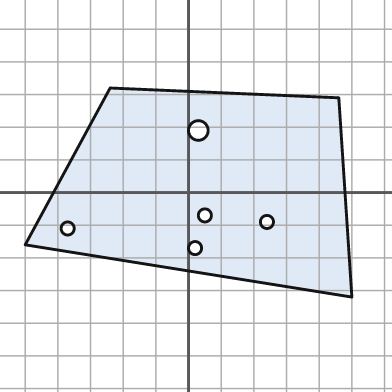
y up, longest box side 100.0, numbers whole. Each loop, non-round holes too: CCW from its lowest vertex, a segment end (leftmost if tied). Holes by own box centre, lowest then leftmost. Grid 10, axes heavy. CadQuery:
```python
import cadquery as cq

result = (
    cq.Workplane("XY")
    .moveTo(50.0, -32.0)
    .lineTo(46.0, 29.0)
    .lineTo(-24.0, 32.0)
    .lineTo(-50.0, -16.0)
    .close()
    .moveTo(2.0, -17.0)
    .circle(2.0)
    .moveTo(-37.0, -11.0)
    .circle(2.0)
    .moveTo(24.0, -9.0)
    .circle(2.0)
    .moveTo(5.0, -7.0)
    .circle(2.0)
    .moveTo(3.0, 19.0)
    .circle(3.0)
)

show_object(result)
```